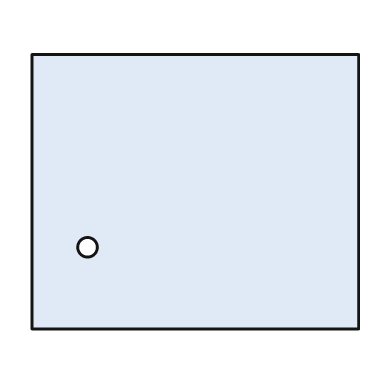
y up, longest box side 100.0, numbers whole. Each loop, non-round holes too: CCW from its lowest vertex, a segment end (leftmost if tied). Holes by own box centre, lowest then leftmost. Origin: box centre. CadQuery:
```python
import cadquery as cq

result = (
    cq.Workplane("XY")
    .moveTo(-50.0, -42.0)
    .lineTo(50.0, -42.0)
    .lineTo(50.0, 42.0)
    .lineTo(-50.0, 42.0)
    .close()
    .moveTo(-33.0, -17.0)
    .circle(3.0)
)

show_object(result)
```